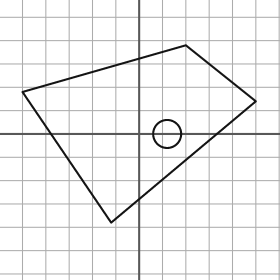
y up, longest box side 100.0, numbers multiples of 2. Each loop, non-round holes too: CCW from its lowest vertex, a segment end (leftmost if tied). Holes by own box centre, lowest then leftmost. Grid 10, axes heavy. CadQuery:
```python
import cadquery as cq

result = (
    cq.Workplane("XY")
    .moveTo(-12.0, -38.0)
    .lineTo(50.0, 14.0)
    .lineTo(20.0, 38.0)
    .lineTo(-50.0, 18.0)
    .close()
    .moveTo(12.0, 0.0)
    .circle(6.0)
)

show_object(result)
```